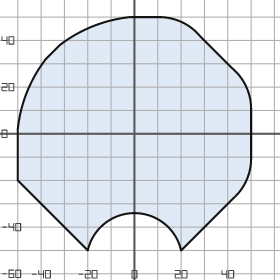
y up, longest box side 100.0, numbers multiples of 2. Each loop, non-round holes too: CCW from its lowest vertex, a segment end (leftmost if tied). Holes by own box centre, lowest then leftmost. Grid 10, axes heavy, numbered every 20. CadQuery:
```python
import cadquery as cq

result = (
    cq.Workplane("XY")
    .moveTo(-20.0, -50.0)
    .threePointArc((0.0, -34.0), (20.0, -50.0))
    .lineTo(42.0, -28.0)
    .threePointArc((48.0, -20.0), (50.0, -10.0))
    .lineTo(50.0, 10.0)
    .threePointArc((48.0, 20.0), (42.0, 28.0))
    .lineTo(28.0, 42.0)
    .threePointArc((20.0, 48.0), (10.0, 50.0))
    .lineTo(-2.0, 50.0)
    .threePointArc((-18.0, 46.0), (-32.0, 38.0))
    .lineTo(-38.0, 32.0)
    .threePointArc((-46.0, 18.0), (-50.0, 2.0))
    .lineTo(-50.0, -20.0)
    .close()
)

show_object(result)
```